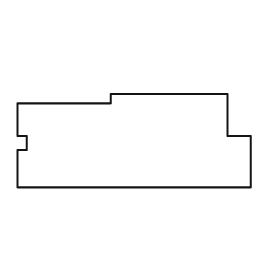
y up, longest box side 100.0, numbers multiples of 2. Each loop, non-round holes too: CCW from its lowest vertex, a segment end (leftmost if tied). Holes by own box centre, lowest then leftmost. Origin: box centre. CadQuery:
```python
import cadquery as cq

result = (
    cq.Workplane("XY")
    .moveTo(-50.0, -20.0)
    .lineTo(50.0, -20.0)
    .lineTo(50.0, 2.0)
    .lineTo(40.0, 2.0)
    .lineTo(40.0, 20.0)
    .lineTo(-10.0, 20.0)
    .lineTo(-10.0, 16.0)
    .lineTo(-50.0, 16.0)
    .lineTo(-50.0, 2.0)
    .lineTo(-46.0, 2.0)
    .lineTo(-46.0, -4.0)
    .lineTo(-50.0, -4.0)
    .close()
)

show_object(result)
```